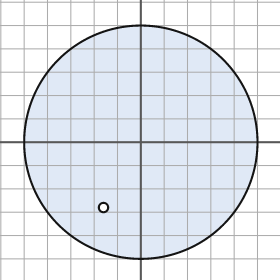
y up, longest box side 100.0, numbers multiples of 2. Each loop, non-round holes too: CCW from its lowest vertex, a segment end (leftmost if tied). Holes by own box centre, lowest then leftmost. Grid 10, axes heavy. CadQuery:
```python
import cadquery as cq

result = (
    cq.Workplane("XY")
    .moveTo(0.0, 0.0)
    .circle(50.0)
    .moveTo(-16.0, -28.0)
    .circle(2.0)
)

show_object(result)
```